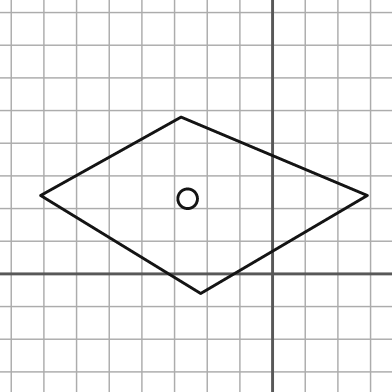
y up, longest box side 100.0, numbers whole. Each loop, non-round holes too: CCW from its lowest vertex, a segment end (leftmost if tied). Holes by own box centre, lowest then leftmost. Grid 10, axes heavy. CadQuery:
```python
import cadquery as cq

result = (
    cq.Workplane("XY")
    .moveTo(-22.0, -6.0)
    .lineTo(29.0, 24.0)
    .lineTo(-28.0, 48.0)
    .lineTo(-71.0, 24.0)
    .close()
    .moveTo(-26.0, 23.0)
    .circle(3.0)
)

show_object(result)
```